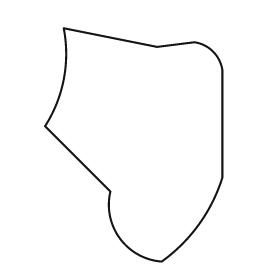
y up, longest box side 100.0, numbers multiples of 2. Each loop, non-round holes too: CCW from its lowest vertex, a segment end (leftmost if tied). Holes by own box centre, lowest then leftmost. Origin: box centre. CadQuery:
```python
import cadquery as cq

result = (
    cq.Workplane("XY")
    .moveTo(12.0, -50.0)
    .threePointArc((28.0, -34.0), (38.0, -14.0))
    .lineTo(38.0, 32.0)
    .threePointArc((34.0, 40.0), (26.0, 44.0))
    .lineTo(10.0, 42.0)
    .lineTo(-30.0, 50.0)
    .threePointArc((-30.0, 28.0), (-38.0, 8.0))
    .lineTo(-10.0, -20.0)
    .threePointArc((-6.0, -40.0), (12.0, -50.0))
    .close()
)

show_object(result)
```